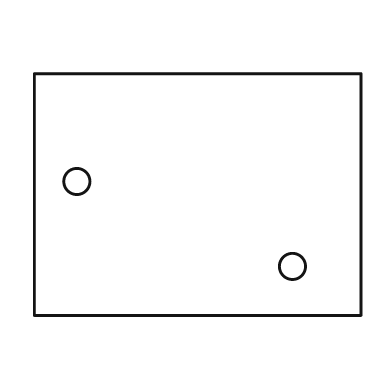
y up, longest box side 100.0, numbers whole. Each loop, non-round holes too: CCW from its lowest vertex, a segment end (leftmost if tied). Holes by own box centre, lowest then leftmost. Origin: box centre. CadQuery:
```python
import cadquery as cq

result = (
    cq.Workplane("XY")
    .moveTo(-50.0, -37.0)
    .lineTo(50.0, -37.0)
    .lineTo(50.0, 37.0)
    .lineTo(-50.0, 37.0)
    .close()
    .moveTo(29.0, -22.0)
    .circle(4.0)
    .moveTo(-37.0, 4.0)
    .circle(4.0)
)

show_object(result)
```